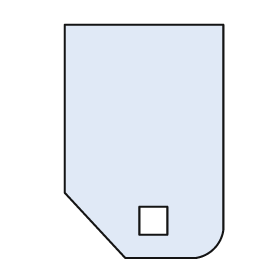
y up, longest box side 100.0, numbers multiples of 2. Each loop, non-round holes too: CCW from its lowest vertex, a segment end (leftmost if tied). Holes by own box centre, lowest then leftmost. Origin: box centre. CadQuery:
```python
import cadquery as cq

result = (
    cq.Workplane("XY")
    .moveTo(-8.0, -50.0)
    .lineTo(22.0, -50.0)
    .threePointArc((30.0, -46.0), (34.0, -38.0))
    .lineTo(34.0, 50.0)
    .lineTo(-34.0, 50.0)
    .lineTo(-34.0, -22.0)
    .close()
    .moveTo(-2.0, -40.0)
    .lineTo(10.0, -40.0)
    .lineTo(10.0, -28.0)
    .lineTo(-2.0, -28.0)
    .close()
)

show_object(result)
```